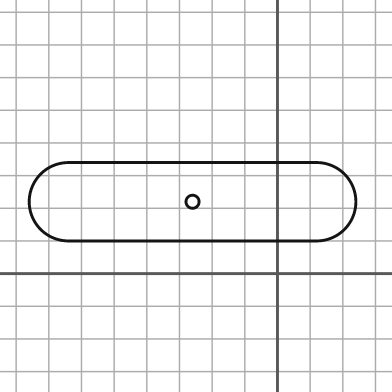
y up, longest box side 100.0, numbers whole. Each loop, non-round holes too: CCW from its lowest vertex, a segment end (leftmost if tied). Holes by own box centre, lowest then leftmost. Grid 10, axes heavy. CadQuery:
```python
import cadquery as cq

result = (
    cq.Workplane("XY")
    .moveTo(-64.0, 10.0)
    .lineTo(12.0, 10.0)
    .threePointArc((24.0, 22.0), (12.0, 34.0))
    .lineTo(-64.0, 34.0)
    .threePointArc((-76.0, 22.0), (-64.0, 10.0))
    .close()
    .moveTo(-26.0, 22.0)
    .circle(2.0)
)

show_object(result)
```